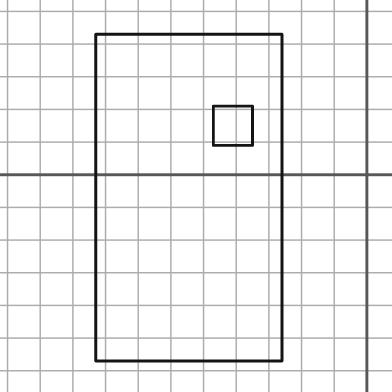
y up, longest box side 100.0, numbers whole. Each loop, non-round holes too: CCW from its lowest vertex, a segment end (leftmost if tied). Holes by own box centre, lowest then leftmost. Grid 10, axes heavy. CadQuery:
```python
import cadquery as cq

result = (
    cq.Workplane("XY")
    .moveTo(-83.0, -57.0)
    .lineTo(-26.0, -57.0)
    .lineTo(-26.0, 43.0)
    .lineTo(-83.0, 43.0)
    .close()
    .moveTo(-47.0, 9.0)
    .lineTo(-35.0, 9.0)
    .lineTo(-35.0, 21.0)
    .lineTo(-47.0, 21.0)
    .close()
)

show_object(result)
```